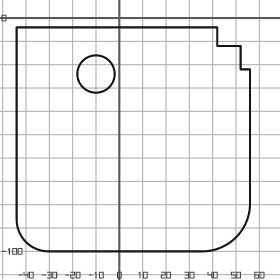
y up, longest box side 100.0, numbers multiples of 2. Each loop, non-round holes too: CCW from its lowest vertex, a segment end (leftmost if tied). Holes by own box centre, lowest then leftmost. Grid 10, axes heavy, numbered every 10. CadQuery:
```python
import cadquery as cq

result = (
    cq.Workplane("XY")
    .moveTo(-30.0, -100.0)
    .lineTo(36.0, -100.0)
    .threePointArc((50.0, -94.0), (56.0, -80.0))
    .lineTo(56.0, -22.0)
    .lineTo(52.0, -22.0)
    .lineTo(52.0, -12.0)
    .lineTo(42.0, -12.0)
    .lineTo(42.0, -4.0)
    .lineTo(-44.0, -4.0)
    .lineTo(-44.0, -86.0)
    .threePointArc((-40.0, -96.0), (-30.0, -100.0))
    .close()
    .moveTo(-10.0, -24.0)
    .circle(8.0)
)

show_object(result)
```